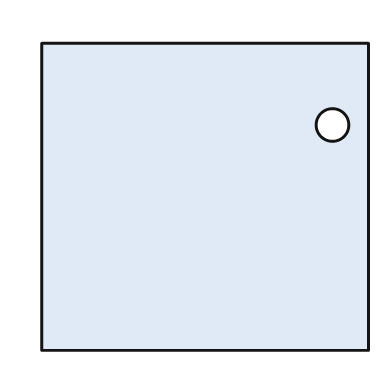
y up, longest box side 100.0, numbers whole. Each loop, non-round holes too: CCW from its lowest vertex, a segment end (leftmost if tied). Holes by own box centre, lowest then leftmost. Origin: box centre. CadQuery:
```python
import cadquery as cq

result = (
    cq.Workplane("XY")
    .moveTo(-50.0, -47.0)
    .lineTo(50.0, -47.0)
    .lineTo(50.0, 47.0)
    .lineTo(-50.0, 47.0)
    .close()
    .moveTo(39.0, 22.0)
    .circle(5.0)
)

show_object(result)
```